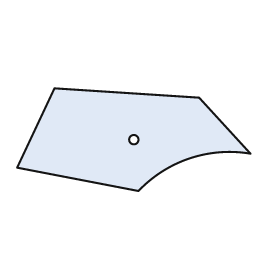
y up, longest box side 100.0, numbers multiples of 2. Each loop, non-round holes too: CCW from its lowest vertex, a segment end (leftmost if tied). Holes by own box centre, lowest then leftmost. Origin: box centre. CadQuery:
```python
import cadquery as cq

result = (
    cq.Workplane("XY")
    .moveTo(2.0, -22.0)
    .threePointArc((24.0, -8.0), (50.0, -6.0))
    .lineTo(28.0, 18.0)
    .lineTo(-34.0, 22.0)
    .lineTo(-50.0, -12.0)
    .close()
    .moveTo(0.0, 0.0)
    .circle(2.0)
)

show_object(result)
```